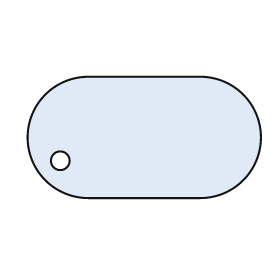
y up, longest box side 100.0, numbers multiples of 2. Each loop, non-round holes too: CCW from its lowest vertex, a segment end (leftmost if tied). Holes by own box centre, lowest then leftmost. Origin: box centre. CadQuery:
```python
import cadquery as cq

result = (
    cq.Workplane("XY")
    .moveTo(-24.0, -26.0)
    .lineTo(24.0, -26.0)
    .threePointArc((50.0, 0.0), (24.0, 26.0))
    .lineTo(-24.0, 26.0)
    .threePointArc((-50.0, 0.0), (-24.0, -26.0))
    .close()
    .moveTo(-36.0, -10.0)
    .circle(4.0)
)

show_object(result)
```